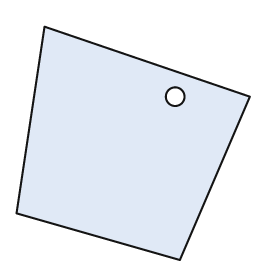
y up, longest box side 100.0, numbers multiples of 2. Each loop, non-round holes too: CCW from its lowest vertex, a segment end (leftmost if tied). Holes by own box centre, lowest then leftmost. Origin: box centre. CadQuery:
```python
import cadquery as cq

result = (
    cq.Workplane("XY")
    .moveTo(20.0, -50.0)
    .lineTo(50.0, 20.0)
    .lineTo(-38.0, 50.0)
    .lineTo(-50.0, -30.0)
    .close()
    .moveTo(18.0, 20.0)
    .circle(4.0)
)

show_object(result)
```